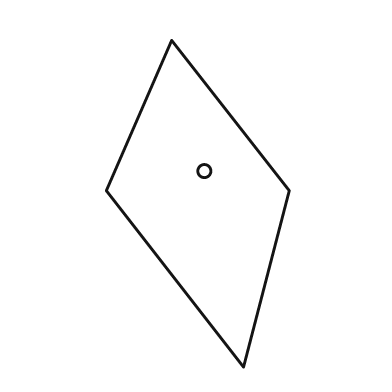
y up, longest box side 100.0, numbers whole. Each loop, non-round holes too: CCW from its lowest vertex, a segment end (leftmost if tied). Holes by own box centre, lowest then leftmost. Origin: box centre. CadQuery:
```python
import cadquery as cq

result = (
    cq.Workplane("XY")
    .moveTo(14.0, -50.0)
    .lineTo(28.0, 4.0)
    .lineTo(-8.0, 50.0)
    .lineTo(-28.0, 4.0)
    .close()
    .moveTo(2.0, 10.0)
    .circle(2.0)
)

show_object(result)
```